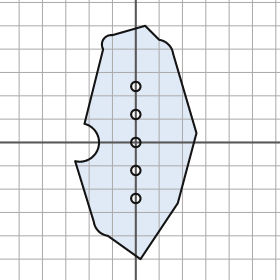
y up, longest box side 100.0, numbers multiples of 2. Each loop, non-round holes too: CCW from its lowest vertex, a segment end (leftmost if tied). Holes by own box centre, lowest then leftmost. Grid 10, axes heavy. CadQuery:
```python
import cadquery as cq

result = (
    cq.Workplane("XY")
    .moveTo(2.0, -50.0)
    .lineTo(18.0, -26.0)
    .lineTo(26.0, 4.0)
    .lineTo(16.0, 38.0)
    .threePointArc((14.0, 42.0), (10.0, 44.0))
    .lineTo(4.0, 50.0)
    .lineTo(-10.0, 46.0)
    .threePointArc((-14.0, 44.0), (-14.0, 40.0))
    .lineTo(-22.0, 8.0)
    .threePointArc((-16.0, -2.0), (-26.0, -8.0))
    .lineTo(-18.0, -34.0)
    .threePointArc((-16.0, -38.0), (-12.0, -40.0))
    .close()
    .moveTo(0.0, -24.0)
    .circle(2.0)
    .moveTo(0.0, -12.0)
    .circle(2.0)
    .moveTo(0.0, 0.0)
    .circle(2.0)
    .moveTo(0.0, 12.0)
    .circle(2.0)
    .moveTo(0.0, 24.0)
    .circle(2.0)
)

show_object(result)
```